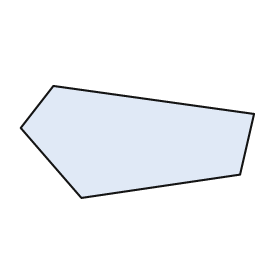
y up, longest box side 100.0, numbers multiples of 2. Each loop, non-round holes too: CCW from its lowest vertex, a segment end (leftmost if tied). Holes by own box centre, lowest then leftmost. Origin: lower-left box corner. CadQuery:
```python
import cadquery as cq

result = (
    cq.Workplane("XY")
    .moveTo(26.0, 0.0)
    .lineTo(94.0, 10.0)
    .lineTo(100.0, 36.0)
    .lineTo(14.0, 48.0)
    .lineTo(0.0, 30.0)
    .close()
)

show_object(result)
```